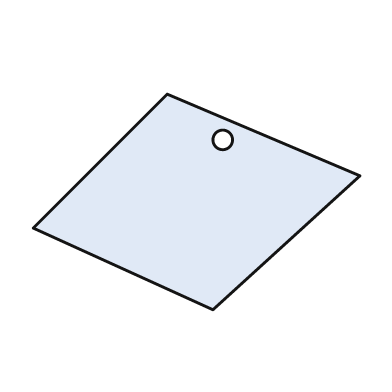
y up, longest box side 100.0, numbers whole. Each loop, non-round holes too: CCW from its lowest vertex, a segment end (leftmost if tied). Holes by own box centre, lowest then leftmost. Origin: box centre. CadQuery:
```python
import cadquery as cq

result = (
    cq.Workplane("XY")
    .moveTo(5.0, -33.0)
    .lineTo(50.0, 8.0)
    .lineTo(-9.0, 33.0)
    .lineTo(-50.0, -8.0)
    .close()
    .moveTo(8.0, 19.0)
    .circle(3.0)
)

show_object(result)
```